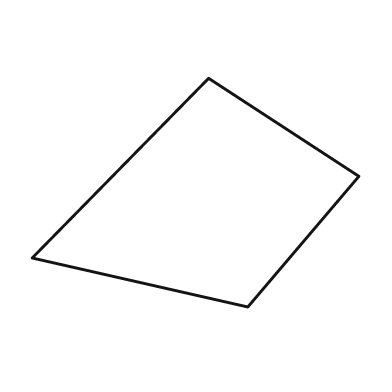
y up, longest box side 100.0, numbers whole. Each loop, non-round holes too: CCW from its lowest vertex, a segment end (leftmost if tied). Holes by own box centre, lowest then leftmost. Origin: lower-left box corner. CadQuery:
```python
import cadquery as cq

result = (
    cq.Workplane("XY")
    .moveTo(66.0, 0.0)
    .lineTo(100.0, 40.0)
    .lineTo(54.0, 70.0)
    .lineTo(0.0, 15.0)
    .close()
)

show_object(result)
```